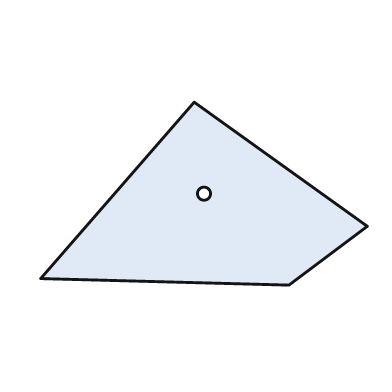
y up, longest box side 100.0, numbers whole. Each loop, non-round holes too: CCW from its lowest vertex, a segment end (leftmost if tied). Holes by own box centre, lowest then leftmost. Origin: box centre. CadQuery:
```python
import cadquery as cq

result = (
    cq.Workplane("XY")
    .moveTo(26.0, -28.0)
    .lineTo(50.0, -10.0)
    .lineTo(-3.0, 28.0)
    .lineTo(-50.0, -26.0)
    .close()
    .moveTo(0.0, 0.0)
    .circle(2.0)
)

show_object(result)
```